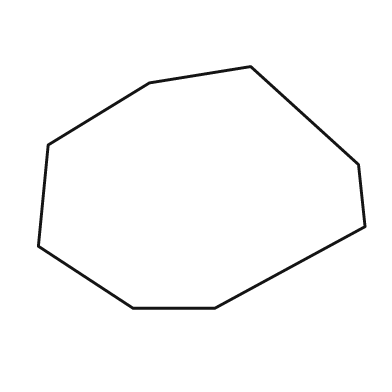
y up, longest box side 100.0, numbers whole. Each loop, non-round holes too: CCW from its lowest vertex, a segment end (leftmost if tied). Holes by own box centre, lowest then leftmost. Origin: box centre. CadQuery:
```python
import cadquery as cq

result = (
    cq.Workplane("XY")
    .moveTo(-21.0, -37.0)
    .lineTo(4.0, -37.0)
    .lineTo(50.0, -12.0)
    .lineTo(48.0, 7.0)
    .lineTo(15.0, 37.0)
    .lineTo(-16.0, 32.0)
    .lineTo(-47.0, 13.0)
    .lineTo(-50.0, -18.0)
    .close()
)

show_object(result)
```